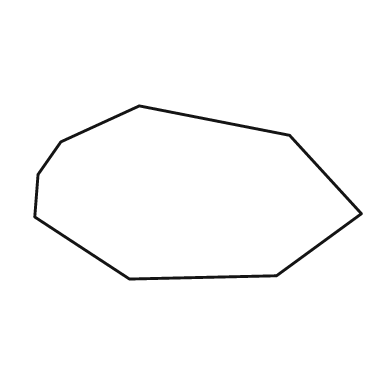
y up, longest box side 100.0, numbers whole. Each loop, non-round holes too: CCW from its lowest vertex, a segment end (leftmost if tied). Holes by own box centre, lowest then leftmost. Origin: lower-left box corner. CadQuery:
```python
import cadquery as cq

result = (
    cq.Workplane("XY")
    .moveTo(29.0, 0.0)
    .lineTo(74.0, 1.0)
    .lineTo(100.0, 20.0)
    .lineTo(78.0, 44.0)
    .lineTo(32.0, 53.0)
    .lineTo(8.0, 42.0)
    .lineTo(1.0, 32.0)
    .lineTo(0.0, 19.0)
    .close()
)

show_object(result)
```